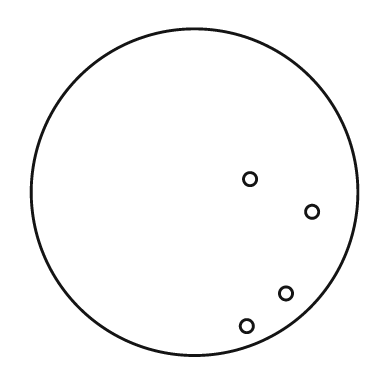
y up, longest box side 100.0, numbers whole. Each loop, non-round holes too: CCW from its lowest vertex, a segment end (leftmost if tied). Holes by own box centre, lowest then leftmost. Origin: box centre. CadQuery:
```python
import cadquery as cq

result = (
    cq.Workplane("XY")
    .moveTo(0.0, 0.0)
    .circle(50.0)
    .moveTo(16.0, -41.0)
    .circle(2.0)
    .moveTo(28.0, -31.0)
    .circle(2.0)
    .moveTo(36.0, -6.0)
    .circle(2.0)
    .moveTo(17.0, 4.0)
    .circle(2.0)
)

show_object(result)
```